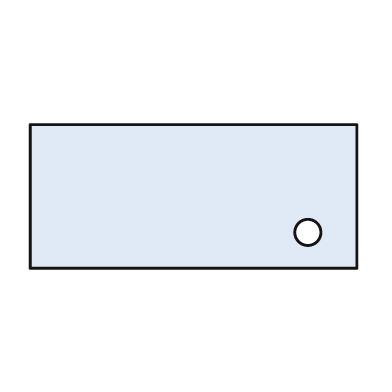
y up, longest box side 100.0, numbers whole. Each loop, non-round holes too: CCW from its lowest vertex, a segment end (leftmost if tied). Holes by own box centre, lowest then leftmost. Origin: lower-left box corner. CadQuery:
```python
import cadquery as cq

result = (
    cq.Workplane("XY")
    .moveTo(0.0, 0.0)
    .lineTo(100.0, 0.0)
    .lineTo(100.0, 44.0)
    .lineTo(0.0, 44.0)
    .close()
    .moveTo(85.0, 11.0)
    .circle(4.0)
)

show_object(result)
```